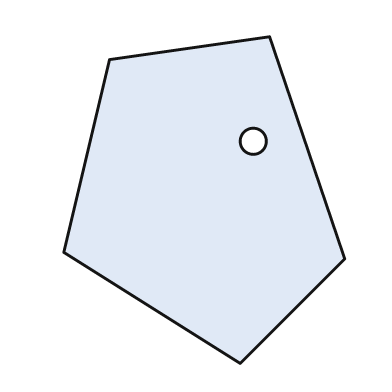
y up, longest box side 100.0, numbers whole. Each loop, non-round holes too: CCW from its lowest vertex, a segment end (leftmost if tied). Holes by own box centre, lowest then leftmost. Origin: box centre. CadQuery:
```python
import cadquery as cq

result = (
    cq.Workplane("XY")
    .moveTo(11.0, -50.0)
    .lineTo(43.0, -18.0)
    .lineTo(20.0, 50.0)
    .lineTo(-29.0, 43.0)
    .lineTo(-43.0, -16.0)
    .close()
    .moveTo(15.0, 18.0)
    .circle(4.0)
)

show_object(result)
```